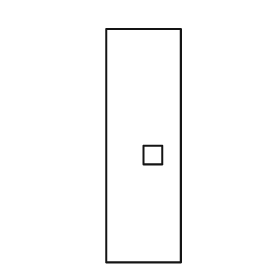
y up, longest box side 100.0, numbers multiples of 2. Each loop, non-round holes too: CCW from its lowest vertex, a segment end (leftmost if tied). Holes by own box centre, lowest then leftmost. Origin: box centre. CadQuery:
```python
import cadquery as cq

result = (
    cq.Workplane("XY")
    .moveTo(-16.0, -50.0)
    .lineTo(16.0, -50.0)
    .lineTo(16.0, 50.0)
    .lineTo(-16.0, 50.0)
    .close()
    .moveTo(0.0, -8.0)
    .lineTo(8.0, -8.0)
    .lineTo(8.0, 0.0)
    .lineTo(0.0, 0.0)
    .close()
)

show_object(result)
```